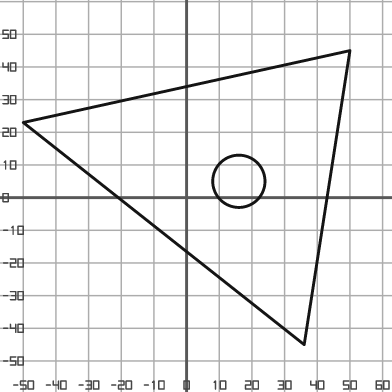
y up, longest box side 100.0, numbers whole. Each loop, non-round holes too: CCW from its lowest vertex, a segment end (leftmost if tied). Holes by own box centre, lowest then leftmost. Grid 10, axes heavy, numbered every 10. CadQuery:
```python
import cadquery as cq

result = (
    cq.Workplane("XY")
    .moveTo(36.0, -45.0)
    .lineTo(50.0, 45.0)
    .lineTo(-50.0, 23.0)
    .close()
    .moveTo(16.0, 5.0)
    .circle(8.0)
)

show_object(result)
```